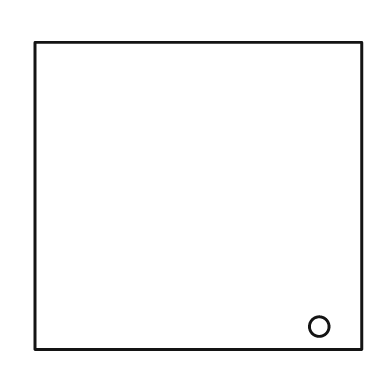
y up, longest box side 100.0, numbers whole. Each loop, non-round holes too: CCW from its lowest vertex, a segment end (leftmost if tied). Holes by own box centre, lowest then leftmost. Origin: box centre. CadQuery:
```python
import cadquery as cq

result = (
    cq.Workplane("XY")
    .moveTo(-50.0, -47.0)
    .lineTo(50.0, -47.0)
    .lineTo(50.0, 47.0)
    .lineTo(-50.0, 47.0)
    .close()
    .moveTo(37.0, -40.0)
    .circle(3.0)
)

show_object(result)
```